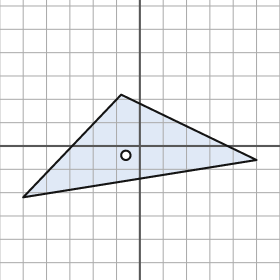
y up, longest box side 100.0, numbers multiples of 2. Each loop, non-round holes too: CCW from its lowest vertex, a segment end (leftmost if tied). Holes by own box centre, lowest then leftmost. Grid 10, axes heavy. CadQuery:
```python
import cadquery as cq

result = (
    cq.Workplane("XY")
    .moveTo(-50.0, -22.0)
    .lineTo(50.0, -6.0)
    .lineTo(-8.0, 22.0)
    .close()
    .moveTo(-6.0, -4.0)
    .circle(2.0)
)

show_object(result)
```